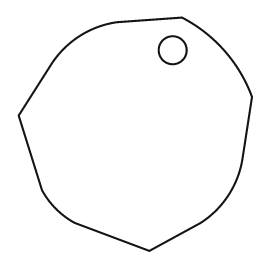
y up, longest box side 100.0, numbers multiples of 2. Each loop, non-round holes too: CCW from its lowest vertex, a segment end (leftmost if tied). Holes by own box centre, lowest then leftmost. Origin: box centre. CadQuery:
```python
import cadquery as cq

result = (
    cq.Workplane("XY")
    .moveTo(6.0, -50.0)
    .lineTo(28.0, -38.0)
    .threePointArc((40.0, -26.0), (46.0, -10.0))
    .lineTo(50.0, 16.0)
    .threePointArc((38.0, 36.0), (20.0, 50.0))
    .lineTo(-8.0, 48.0)
    .threePointArc((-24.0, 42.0), (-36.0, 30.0))
    .lineTo(-50.0, 8.0)
    .lineTo(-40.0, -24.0)
    .threePointArc((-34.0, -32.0), (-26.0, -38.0))
    .close()
    .moveTo(16.0, 36.0)
    .circle(6.0)
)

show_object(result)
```